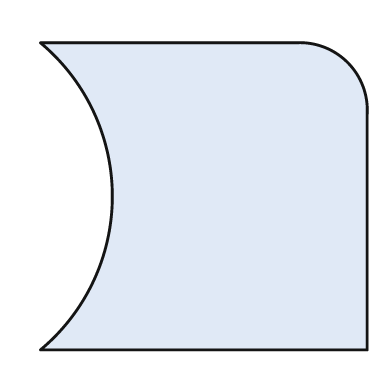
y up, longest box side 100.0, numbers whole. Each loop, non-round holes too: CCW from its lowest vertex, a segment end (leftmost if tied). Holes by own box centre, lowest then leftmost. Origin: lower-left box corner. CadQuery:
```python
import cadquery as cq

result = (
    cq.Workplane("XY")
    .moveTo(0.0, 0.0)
    .lineTo(100.0, 0.0)
    .lineTo(100.0, 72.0)
    .threePointArc((94.0, 88.0), (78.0, 94.0))
    .lineTo(0.0, 94.0)
    .threePointArc((22.0, 47.0), (0.0, 0.0))
    .close()
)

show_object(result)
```